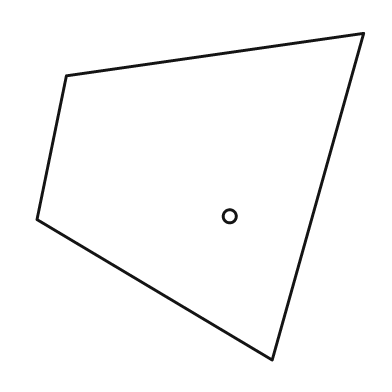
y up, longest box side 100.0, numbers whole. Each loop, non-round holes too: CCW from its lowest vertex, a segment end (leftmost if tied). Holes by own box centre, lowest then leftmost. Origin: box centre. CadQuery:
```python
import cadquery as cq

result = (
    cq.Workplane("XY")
    .moveTo(22.0, -50.0)
    .lineTo(50.0, 50.0)
    .lineTo(-41.0, 37.0)
    .lineTo(-50.0, -7.0)
    .close()
    .moveTo(9.0, -6.0)
    .circle(2.0)
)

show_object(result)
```